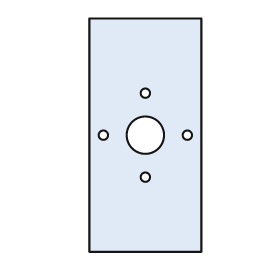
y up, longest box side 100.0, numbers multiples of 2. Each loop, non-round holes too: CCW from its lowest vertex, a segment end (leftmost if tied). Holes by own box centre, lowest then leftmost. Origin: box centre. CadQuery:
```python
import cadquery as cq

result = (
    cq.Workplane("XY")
    .moveTo(-24.0, -50.0)
    .lineTo(24.0, -50.0)
    .lineTo(24.0, 50.0)
    .lineTo(-24.0, 50.0)
    .close()
    .moveTo(0.0, -18.0)
    .circle(2.0)
    .moveTo(-18.0, 0.0)
    .circle(2.0)
    .moveTo(0.0, 0.0)
    .circle(8.0)
    .moveTo(18.0, 0.0)
    .circle(2.0)
    .moveTo(0.0, 18.0)
    .circle(2.0)
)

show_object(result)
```